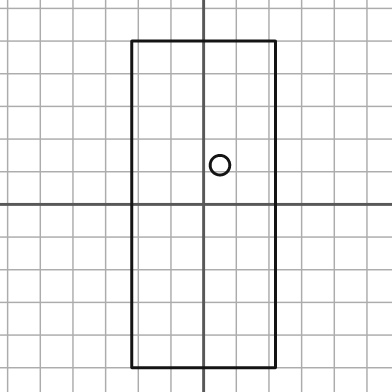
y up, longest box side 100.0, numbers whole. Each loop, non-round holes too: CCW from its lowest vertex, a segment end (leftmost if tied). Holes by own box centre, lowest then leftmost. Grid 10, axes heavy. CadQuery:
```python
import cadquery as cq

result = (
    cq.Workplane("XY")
    .moveTo(-22.0, -50.0)
    .lineTo(22.0, -50.0)
    .lineTo(22.0, 50.0)
    .lineTo(-22.0, 50.0)
    .close()
    .moveTo(5.0, 12.0)
    .circle(3.0)
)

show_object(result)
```